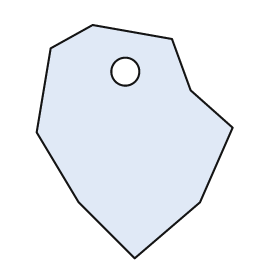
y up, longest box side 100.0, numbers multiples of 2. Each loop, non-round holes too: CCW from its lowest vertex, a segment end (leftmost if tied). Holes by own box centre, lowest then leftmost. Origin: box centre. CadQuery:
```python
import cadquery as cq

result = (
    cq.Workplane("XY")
    .moveTo(0.0, -50.0)
    .lineTo(28.0, -26.0)
    .lineTo(42.0, 6.0)
    .lineTo(24.0, 22.0)
    .lineTo(16.0, 44.0)
    .lineTo(-18.0, 50.0)
    .lineTo(-36.0, 40.0)
    .lineTo(-42.0, 4.0)
    .lineTo(-24.0, -26.0)
    .close()
    .moveTo(-4.0, 30.0)
    .circle(6.0)
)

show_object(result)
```